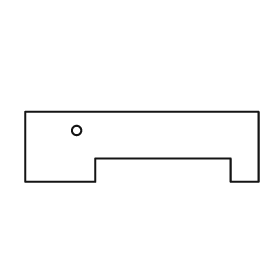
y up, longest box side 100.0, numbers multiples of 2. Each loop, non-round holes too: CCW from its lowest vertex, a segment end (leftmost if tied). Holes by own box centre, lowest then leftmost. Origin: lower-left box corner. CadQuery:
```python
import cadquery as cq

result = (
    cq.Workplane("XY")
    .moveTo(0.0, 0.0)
    .lineTo(30.0, 0.0)
    .lineTo(30.0, 10.0)
    .lineTo(88.0, 10.0)
    .lineTo(88.0, 0.0)
    .lineTo(100.0, 0.0)
    .lineTo(100.0, 30.0)
    .lineTo(0.0, 30.0)
    .close()
    .moveTo(22.0, 22.0)
    .circle(2.0)
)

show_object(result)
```